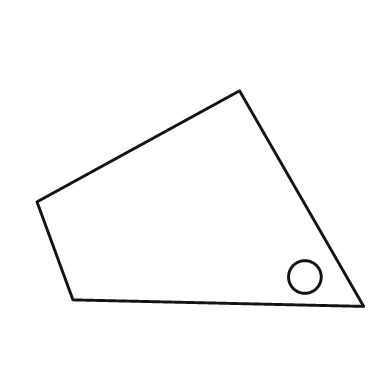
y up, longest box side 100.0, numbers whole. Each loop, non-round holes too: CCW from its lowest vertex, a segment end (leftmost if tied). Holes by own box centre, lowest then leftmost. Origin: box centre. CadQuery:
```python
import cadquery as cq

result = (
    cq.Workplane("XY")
    .moveTo(50.0, -33.0)
    .lineTo(12.0, 33.0)
    .lineTo(-50.0, -1.0)
    .lineTo(-39.0, -31.0)
    .close()
    .moveTo(32.0, -24.0)
    .circle(5.0)
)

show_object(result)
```